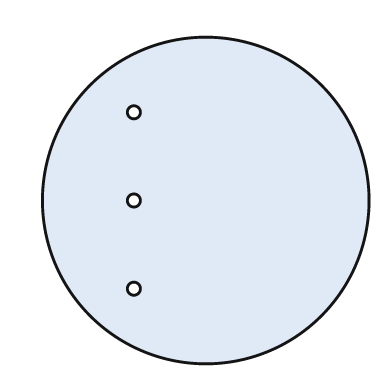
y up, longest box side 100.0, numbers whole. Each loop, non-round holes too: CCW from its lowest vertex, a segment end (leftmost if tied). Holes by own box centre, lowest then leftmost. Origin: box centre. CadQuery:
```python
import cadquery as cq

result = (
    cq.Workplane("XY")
    .moveTo(0.0, 0.0)
    .circle(50.0)
    .moveTo(-22.0, -27.0)
    .circle(2.0)
    .moveTo(-22.0, 0.0)
    .circle(2.0)
    .moveTo(-22.0, 27.0)
    .circle(2.0)
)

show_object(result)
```